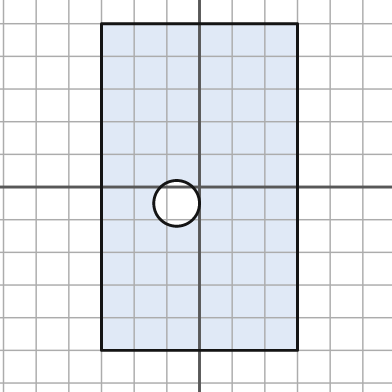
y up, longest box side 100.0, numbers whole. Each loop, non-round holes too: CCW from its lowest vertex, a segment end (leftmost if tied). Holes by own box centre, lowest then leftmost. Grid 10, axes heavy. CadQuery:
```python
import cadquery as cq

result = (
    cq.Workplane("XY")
    .moveTo(-30.0, -50.0)
    .lineTo(30.0, -50.0)
    .lineTo(30.0, 50.0)
    .lineTo(-30.0, 50.0)
    .close()
    .moveTo(-7.0, -5.0)
    .circle(7.0)
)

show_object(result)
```